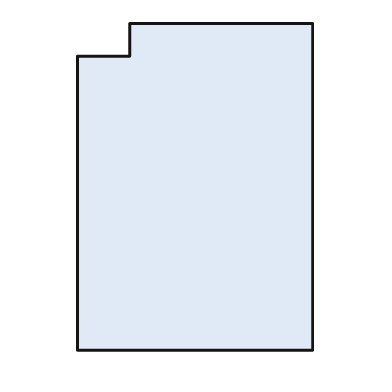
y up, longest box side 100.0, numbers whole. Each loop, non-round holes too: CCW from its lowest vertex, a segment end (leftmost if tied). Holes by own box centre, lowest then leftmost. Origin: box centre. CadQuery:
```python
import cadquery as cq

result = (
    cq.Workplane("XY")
    .moveTo(-36.0, -50.0)
    .lineTo(36.0, -50.0)
    .lineTo(36.0, 50.0)
    .lineTo(-20.0, 50.0)
    .lineTo(-20.0, 40.0)
    .lineTo(-36.0, 40.0)
    .close()
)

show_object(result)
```